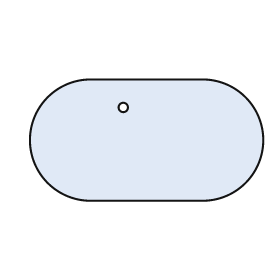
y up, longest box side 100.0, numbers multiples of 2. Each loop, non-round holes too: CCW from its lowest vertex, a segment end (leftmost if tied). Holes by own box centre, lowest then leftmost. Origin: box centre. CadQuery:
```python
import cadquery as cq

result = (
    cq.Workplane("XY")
    .moveTo(-24.0, -26.0)
    .lineTo(24.0, -26.0)
    .threePointArc((50.0, 0.0), (24.0, 26.0))
    .lineTo(-24.0, 26.0)
    .threePointArc((-50.0, 0.0), (-24.0, -26.0))
    .close()
    .moveTo(-10.0, 14.0)
    .circle(2.0)
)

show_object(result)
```